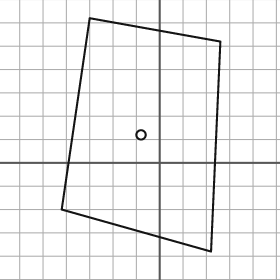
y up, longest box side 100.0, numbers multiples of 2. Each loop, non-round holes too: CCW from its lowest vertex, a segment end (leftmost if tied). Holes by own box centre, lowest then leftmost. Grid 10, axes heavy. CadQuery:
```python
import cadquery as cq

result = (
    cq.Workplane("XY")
    .moveTo(22.0, -38.0)
    .lineTo(26.0, 52.0)
    .lineTo(-30.0, 62.0)
    .lineTo(-42.0, -20.0)
    .close()
    .moveTo(-8.0, 12.0)
    .circle(2.0)
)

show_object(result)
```